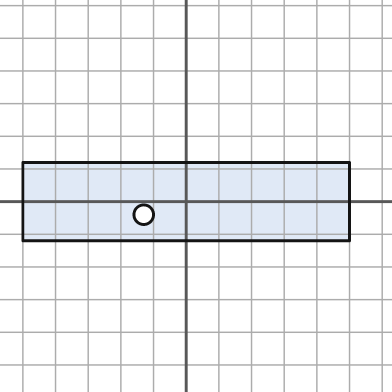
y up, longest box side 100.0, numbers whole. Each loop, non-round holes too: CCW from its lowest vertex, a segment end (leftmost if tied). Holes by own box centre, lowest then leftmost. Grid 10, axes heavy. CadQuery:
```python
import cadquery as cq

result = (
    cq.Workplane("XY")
    .moveTo(-50.0, -12.0)
    .lineTo(50.0, -12.0)
    .lineTo(50.0, 12.0)
    .lineTo(-50.0, 12.0)
    .close()
    .moveTo(-13.0, -4.0)
    .circle(3.0)
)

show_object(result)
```